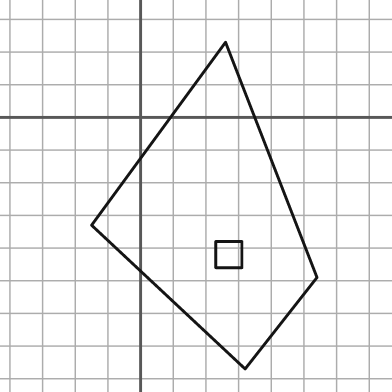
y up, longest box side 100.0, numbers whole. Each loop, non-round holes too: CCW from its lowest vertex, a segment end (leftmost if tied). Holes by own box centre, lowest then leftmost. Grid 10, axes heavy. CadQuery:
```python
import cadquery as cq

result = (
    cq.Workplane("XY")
    .moveTo(32.0, -77.0)
    .lineTo(54.0, -49.0)
    .lineTo(26.0, 23.0)
    .lineTo(-15.0, -33.0)
    .close()
    .moveTo(23.0, -46.0)
    .lineTo(31.0, -46.0)
    .lineTo(31.0, -38.0)
    .lineTo(23.0, -38.0)
    .close()
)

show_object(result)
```